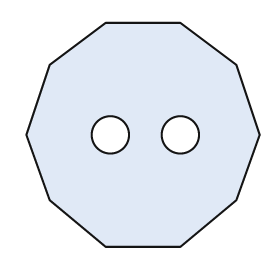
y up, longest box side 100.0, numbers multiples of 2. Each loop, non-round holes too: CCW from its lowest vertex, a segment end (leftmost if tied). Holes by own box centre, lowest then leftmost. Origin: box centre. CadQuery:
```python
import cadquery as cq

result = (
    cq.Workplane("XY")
    .moveTo(-16.0, -48.0)
    .lineTo(16.0, -48.0)
    .lineTo(40.0, -28.0)
    .lineTo(50.0, 0.0)
    .lineTo(40.0, 30.0)
    .lineTo(16.0, 48.0)
    .lineTo(-16.0, 48.0)
    .lineTo(-40.0, 30.0)
    .lineTo(-50.0, 0.0)
    .lineTo(-40.0, -28.0)
    .close()
    .moveTo(-14.0, 0.0)
    .circle(8.0)
    .moveTo(16.0, 0.0)
    .circle(8.0)
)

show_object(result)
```